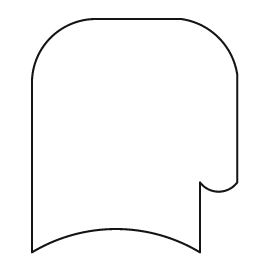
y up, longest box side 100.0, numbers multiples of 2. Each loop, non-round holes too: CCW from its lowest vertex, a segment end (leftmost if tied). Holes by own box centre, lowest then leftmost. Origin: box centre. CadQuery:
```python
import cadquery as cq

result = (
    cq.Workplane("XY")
    .moveTo(-44.0, -50.0)
    .threePointArc((-8.0, -40.0), (28.0, -50.0))
    .lineTo(28.0, -20.0)
    .threePointArc((36.0, -24.0), (44.0, -20.0))
    .lineTo(44.0, 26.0)
    .threePointArc((36.0, 42.0), (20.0, 50.0))
    .lineTo(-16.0, 50.0)
    .threePointArc((-36.0, 42.0), (-44.0, 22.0))
    .close()
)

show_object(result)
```